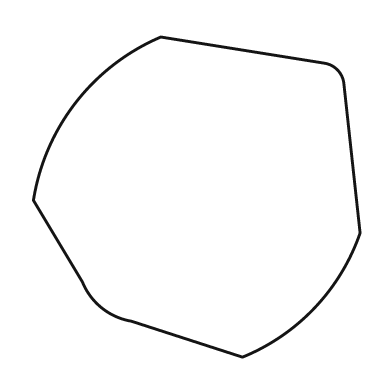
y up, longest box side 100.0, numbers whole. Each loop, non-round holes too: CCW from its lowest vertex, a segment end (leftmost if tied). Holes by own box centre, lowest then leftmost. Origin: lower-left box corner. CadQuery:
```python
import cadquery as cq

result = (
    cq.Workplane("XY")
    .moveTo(64.0, 0.0)
    .threePointArc((86.0, 15.0), (100.0, 38.0))
    .lineTo(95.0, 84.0)
    .threePointArc((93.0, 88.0), (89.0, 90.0))
    .lineTo(39.0, 98.0)
    .threePointArc((13.0, 78.0), (0.0, 48.0))
    .lineTo(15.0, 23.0)
    .threePointArc((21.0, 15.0), (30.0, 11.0))
    .close()
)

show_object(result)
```